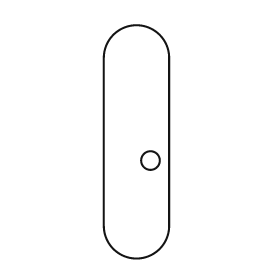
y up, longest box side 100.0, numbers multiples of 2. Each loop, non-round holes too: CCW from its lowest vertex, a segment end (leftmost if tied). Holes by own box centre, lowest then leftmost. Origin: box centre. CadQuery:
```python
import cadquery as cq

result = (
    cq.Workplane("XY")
    .moveTo(-14.0, -36.0)
    .threePointArc((0.0, -50.0), (14.0, -36.0))
    .lineTo(14.0, 36.0)
    .threePointArc((0.0, 50.0), (-14.0, 36.0))
    .close()
    .moveTo(6.0, -8.0)
    .circle(4.0)
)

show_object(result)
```